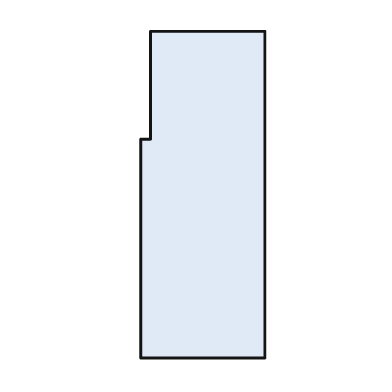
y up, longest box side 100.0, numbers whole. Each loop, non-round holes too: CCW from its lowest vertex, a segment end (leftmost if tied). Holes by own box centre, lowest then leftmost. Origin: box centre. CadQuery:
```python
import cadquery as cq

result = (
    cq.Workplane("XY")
    .moveTo(-19.0, -50.0)
    .lineTo(19.0, -50.0)
    .lineTo(19.0, 50.0)
    .lineTo(-16.0, 50.0)
    .lineTo(-16.0, 17.0)
    .lineTo(-19.0, 17.0)
    .close()
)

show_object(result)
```